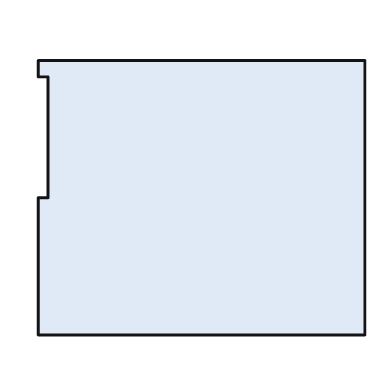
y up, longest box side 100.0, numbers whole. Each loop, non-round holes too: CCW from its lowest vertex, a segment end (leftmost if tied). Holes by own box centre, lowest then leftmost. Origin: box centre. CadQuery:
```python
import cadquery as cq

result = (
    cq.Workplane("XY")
    .moveTo(-50.0, -42.0)
    .lineTo(50.0, -42.0)
    .lineTo(50.0, 42.0)
    .lineTo(-50.0, 42.0)
    .lineTo(-50.0, 37.0)
    .lineTo(-47.0, 37.0)
    .lineTo(-47.0, 0.0)
    .lineTo(-50.0, 0.0)
    .close()
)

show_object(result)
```